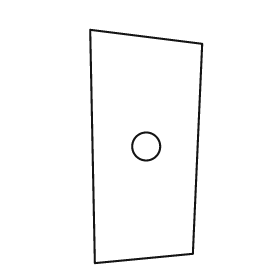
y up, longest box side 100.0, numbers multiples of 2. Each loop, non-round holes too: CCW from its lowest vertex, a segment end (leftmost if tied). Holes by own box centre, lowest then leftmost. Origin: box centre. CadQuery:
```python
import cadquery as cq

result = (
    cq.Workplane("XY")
    .moveTo(-22.0, -50.0)
    .lineTo(20.0, -46.0)
    .lineTo(24.0, 44.0)
    .lineTo(-24.0, 50.0)
    .close()
    .moveTo(0.0, 0.0)
    .circle(6.0)
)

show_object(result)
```